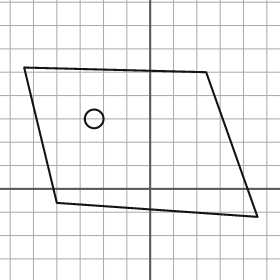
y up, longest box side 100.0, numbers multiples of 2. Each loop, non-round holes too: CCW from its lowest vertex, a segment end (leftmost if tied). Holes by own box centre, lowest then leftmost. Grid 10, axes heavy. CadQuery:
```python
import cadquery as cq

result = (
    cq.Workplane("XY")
    .moveTo(46.0, -12.0)
    .lineTo(24.0, 50.0)
    .lineTo(-54.0, 52.0)
    .lineTo(-40.0, -6.0)
    .close()
    .moveTo(-24.0, 30.0)
    .circle(4.0)
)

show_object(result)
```